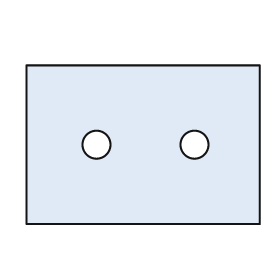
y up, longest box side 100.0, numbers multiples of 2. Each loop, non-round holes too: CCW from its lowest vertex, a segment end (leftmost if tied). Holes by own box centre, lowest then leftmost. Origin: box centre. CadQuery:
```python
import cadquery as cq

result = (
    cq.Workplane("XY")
    .moveTo(-50.0, -34.0)
    .lineTo(50.0, -34.0)
    .lineTo(50.0, 34.0)
    .lineTo(-50.0, 34.0)
    .close()
    .moveTo(-20.0, 0.0)
    .circle(6.0)
    .moveTo(22.0, 0.0)
    .circle(6.0)
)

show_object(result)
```